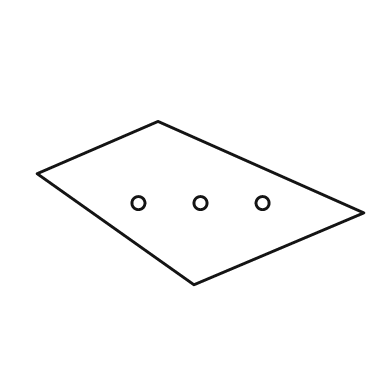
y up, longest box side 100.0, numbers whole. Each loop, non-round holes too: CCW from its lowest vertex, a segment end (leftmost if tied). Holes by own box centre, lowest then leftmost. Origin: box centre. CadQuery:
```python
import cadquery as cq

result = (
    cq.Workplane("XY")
    .moveTo(-2.0, -25.0)
    .lineTo(50.0, -3.0)
    .lineTo(-13.0, 25.0)
    .lineTo(-50.0, 9.0)
    .close()
    .moveTo(-19.0, 0.0)
    .circle(2.0)
    .moveTo(0.0, 0.0)
    .circle(2.0)
    .moveTo(19.0, 0.0)
    .circle(2.0)
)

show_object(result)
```